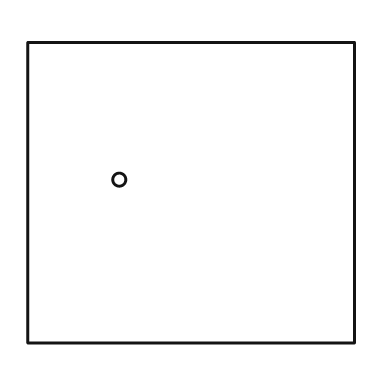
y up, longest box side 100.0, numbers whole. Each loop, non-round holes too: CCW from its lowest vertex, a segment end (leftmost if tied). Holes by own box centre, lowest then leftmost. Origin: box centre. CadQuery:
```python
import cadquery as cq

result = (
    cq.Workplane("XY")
    .moveTo(-50.0, -46.0)
    .lineTo(50.0, -46.0)
    .lineTo(50.0, 46.0)
    .lineTo(-50.0, 46.0)
    .close()
    .moveTo(-22.0, 4.0)
    .circle(2.0)
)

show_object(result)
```